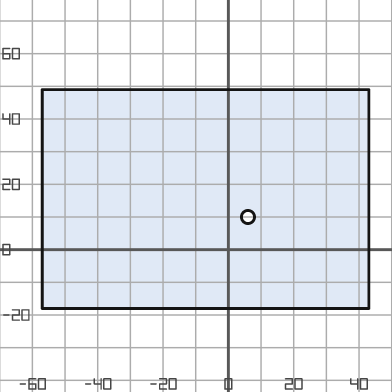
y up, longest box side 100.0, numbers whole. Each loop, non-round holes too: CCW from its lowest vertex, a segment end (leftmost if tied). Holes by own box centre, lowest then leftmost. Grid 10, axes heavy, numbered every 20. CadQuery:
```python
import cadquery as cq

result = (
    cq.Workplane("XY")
    .moveTo(-57.0, -18.0)
    .lineTo(43.0, -18.0)
    .lineTo(43.0, 49.0)
    .lineTo(-57.0, 49.0)
    .close()
    .moveTo(6.0, 10.0)
    .circle(2.0)
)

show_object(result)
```